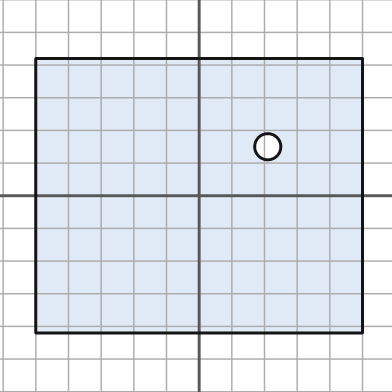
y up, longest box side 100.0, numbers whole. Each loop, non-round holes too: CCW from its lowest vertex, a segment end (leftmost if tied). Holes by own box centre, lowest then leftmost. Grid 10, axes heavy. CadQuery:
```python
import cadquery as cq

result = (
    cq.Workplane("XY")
    .moveTo(-50.0, -42.0)
    .lineTo(50.0, -42.0)
    .lineTo(50.0, 42.0)
    .lineTo(-50.0, 42.0)
    .close()
    .moveTo(21.0, 15.0)
    .circle(4.0)
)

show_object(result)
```